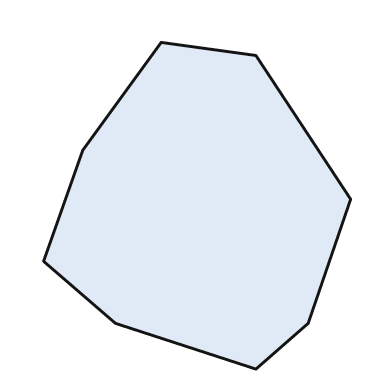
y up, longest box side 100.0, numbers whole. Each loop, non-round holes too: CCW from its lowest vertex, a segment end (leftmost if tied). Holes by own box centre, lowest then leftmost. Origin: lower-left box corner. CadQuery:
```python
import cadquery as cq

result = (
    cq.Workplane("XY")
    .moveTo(65.0, 0.0)
    .lineTo(81.0, 14.0)
    .lineTo(94.0, 52.0)
    .lineTo(65.0, 96.0)
    .lineTo(36.0, 100.0)
    .lineTo(12.0, 67.0)
    .lineTo(0.0, 33.0)
    .lineTo(22.0, 14.0)
    .close()
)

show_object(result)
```